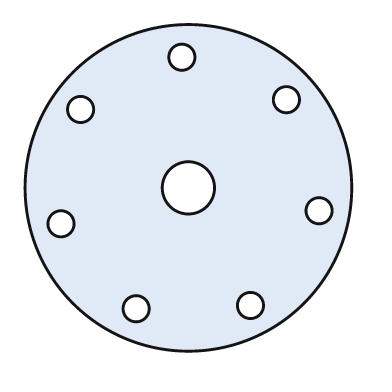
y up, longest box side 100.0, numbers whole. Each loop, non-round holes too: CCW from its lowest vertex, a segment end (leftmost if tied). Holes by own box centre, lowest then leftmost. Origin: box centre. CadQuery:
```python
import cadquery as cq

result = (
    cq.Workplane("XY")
    .moveTo(0.0, 0.0)
    .circle(50.0)
    .moveTo(-16.0, -37.0)
    .circle(4.0)
    .moveTo(19.0, -36.0)
    .circle(4.0)
    .moveTo(-39.0, -11.0)
    .circle(4.0)
    .moveTo(40.0, -7.0)
    .circle(4.0)
    .moveTo(0.0, 0.0)
    .circle(8.0)
    .moveTo(-33.0, 24.0)
    .circle(4.0)
    .moveTo(30.0, 27.0)
    .circle(4.0)
    .moveTo(-2.0, 40.0)
    .circle(4.0)
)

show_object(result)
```